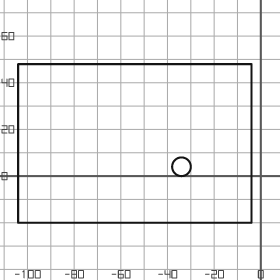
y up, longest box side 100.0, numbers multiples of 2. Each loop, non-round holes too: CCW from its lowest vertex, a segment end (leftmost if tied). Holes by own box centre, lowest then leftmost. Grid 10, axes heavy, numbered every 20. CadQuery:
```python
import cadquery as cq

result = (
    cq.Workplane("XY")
    .moveTo(-104.0, -20.0)
    .lineTo(-4.0, -20.0)
    .lineTo(-4.0, 48.0)
    .lineTo(-104.0, 48.0)
    .close()
    .moveTo(-34.0, 4.0)
    .circle(4.0)
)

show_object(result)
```